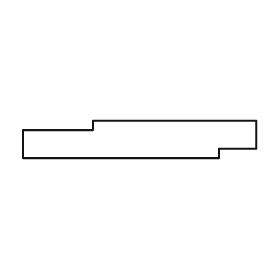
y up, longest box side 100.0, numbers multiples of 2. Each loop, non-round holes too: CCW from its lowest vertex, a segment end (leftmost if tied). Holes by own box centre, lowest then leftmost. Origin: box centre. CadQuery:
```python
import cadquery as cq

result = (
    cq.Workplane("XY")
    .moveTo(-50.0, -8.0)
    .lineTo(34.0, -8.0)
    .lineTo(34.0, -4.0)
    .lineTo(50.0, -4.0)
    .lineTo(50.0, 8.0)
    .lineTo(-20.0, 8.0)
    .lineTo(-20.0, 4.0)
    .lineTo(-50.0, 4.0)
    .close()
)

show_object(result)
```